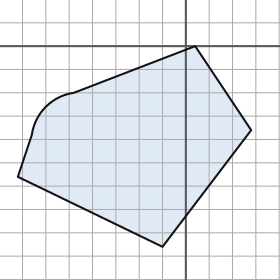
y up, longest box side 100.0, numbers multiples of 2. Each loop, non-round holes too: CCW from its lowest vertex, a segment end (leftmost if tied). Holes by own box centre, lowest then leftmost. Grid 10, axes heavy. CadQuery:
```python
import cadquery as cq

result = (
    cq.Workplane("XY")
    .moveTo(-10.0, -86.0)
    .lineTo(28.0, -36.0)
    .lineTo(4.0, 0.0)
    .lineTo(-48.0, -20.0)
    .threePointArc((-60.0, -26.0), (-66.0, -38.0))
    .lineTo(-72.0, -56.0)
    .close()
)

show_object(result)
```